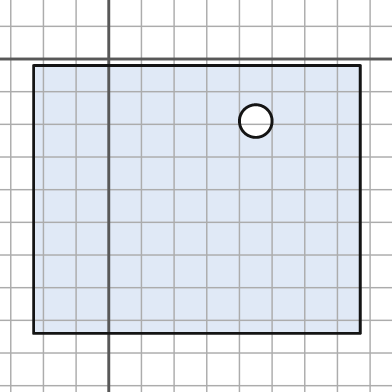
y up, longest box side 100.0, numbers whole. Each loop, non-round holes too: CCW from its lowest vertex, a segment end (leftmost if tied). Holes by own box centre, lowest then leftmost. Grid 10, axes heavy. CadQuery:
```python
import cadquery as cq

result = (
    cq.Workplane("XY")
    .moveTo(-23.0, -84.0)
    .lineTo(77.0, -84.0)
    .lineTo(77.0, -2.0)
    .lineTo(-23.0, -2.0)
    .close()
    .moveTo(45.0, -19.0)
    .circle(5.0)
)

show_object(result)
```